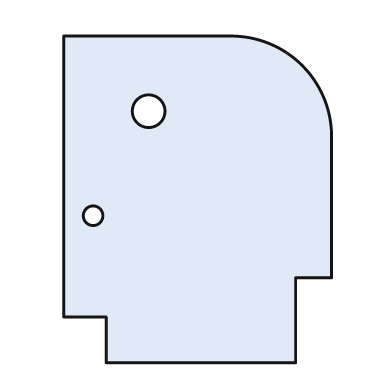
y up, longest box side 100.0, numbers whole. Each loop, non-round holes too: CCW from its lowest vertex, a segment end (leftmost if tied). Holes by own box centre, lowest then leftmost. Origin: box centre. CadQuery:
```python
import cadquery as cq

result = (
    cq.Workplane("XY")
    .moveTo(-28.0, -50.0)
    .lineTo(30.0, -50.0)
    .lineTo(30.0, -24.0)
    .lineTo(41.0, -24.0)
    .lineTo(41.0, 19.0)
    .threePointArc((32.0, 41.0), (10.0, 50.0))
    .lineTo(-41.0, 50.0)
    .lineTo(-41.0, -36.0)
    .lineTo(-28.0, -36.0)
    .close()
    .moveTo(-32.0, -5.0)
    .circle(3.0)
    .moveTo(-15.0, 27.0)
    .circle(5.0)
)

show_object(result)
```